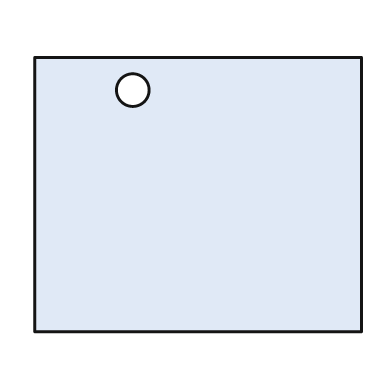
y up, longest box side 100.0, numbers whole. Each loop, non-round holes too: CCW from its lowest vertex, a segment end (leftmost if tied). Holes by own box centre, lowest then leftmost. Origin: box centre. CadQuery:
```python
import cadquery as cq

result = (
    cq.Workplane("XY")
    .moveTo(-50.0, -42.0)
    .lineTo(50.0, -42.0)
    .lineTo(50.0, 42.0)
    .lineTo(-50.0, 42.0)
    .close()
    .moveTo(-20.0, 32.0)
    .circle(5.0)
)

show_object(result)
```